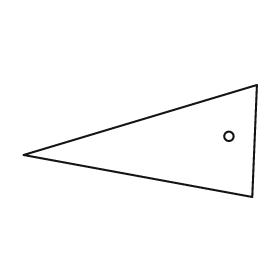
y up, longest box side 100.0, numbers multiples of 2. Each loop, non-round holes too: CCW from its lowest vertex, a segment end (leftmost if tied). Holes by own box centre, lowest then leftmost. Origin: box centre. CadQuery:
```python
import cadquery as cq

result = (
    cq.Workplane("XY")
    .moveTo(48.0, -24.0)
    .lineTo(50.0, 24.0)
    .lineTo(-50.0, -6.0)
    .close()
    .moveTo(38.0, 2.0)
    .circle(2.0)
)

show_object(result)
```